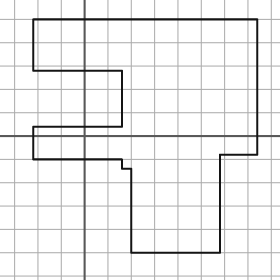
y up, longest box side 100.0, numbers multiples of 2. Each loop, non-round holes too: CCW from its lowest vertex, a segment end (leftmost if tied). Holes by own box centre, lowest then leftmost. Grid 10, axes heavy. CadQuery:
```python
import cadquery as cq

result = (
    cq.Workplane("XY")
    .moveTo(20.0, -50.0)
    .lineTo(58.0, -50.0)
    .lineTo(58.0, -8.0)
    .lineTo(74.0, -8.0)
    .lineTo(74.0, 50.0)
    .lineTo(-22.0, 50.0)
    .lineTo(-22.0, 28.0)
    .lineTo(16.0, 28.0)
    .lineTo(16.0, 4.0)
    .lineTo(-22.0, 4.0)
    .lineTo(-22.0, -10.0)
    .lineTo(16.0, -10.0)
    .lineTo(16.0, -14.0)
    .lineTo(20.0, -14.0)
    .close()
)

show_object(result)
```